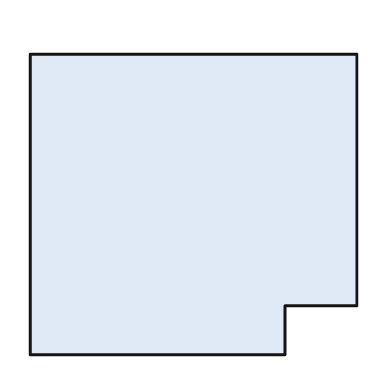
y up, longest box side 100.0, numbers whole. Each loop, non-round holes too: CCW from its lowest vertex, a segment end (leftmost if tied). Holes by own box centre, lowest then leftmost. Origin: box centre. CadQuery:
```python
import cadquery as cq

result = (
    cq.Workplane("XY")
    .moveTo(-50.0, -46.0)
    .lineTo(28.0, -46.0)
    .lineTo(28.0, -31.0)
    .lineTo(50.0, -31.0)
    .lineTo(50.0, 46.0)
    .lineTo(-50.0, 46.0)
    .close()
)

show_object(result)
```